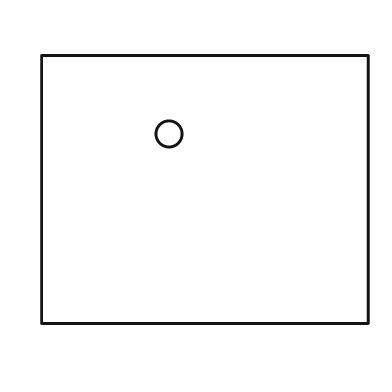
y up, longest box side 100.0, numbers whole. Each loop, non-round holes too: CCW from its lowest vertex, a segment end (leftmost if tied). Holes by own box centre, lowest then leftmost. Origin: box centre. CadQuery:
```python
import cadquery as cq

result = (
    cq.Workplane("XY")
    .moveTo(-50.0, -41.0)
    .lineTo(50.0, -41.0)
    .lineTo(50.0, 41.0)
    .lineTo(-50.0, 41.0)
    .close()
    .moveTo(-11.0, 17.0)
    .circle(4.0)
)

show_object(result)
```